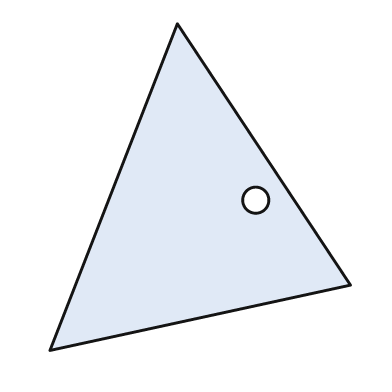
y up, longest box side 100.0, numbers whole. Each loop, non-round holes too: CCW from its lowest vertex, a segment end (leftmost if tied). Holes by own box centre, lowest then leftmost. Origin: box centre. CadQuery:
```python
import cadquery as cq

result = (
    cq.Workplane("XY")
    .moveTo(-46.0, -50.0)
    .lineTo(46.0, -30.0)
    .lineTo(-7.0, 50.0)
    .close()
    .moveTo(17.0, -4.0)
    .circle(4.0)
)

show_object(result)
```